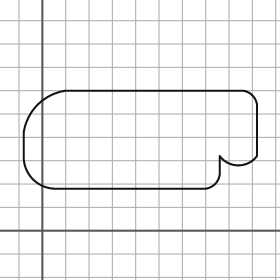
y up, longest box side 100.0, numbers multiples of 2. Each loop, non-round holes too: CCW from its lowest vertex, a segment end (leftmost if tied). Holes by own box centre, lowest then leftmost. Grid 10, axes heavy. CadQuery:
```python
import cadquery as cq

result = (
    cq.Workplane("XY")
    .moveTo(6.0, 18.0)
    .lineTo(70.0, 18.0)
    .threePointArc((74.0, 20.0), (76.0, 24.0))
    .lineTo(76.0, 32.0)
    .threePointArc((84.0, 28.0), (92.0, 32.0))
    .lineTo(92.0, 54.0)
    .threePointArc((90.0, 58.0), (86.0, 60.0))
    .lineTo(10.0, 60.0)
    .threePointArc((-2.0, 54.0), (-8.0, 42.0))
    .lineTo(-8.0, 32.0)
    .threePointArc((-4.0, 22.0), (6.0, 18.0))
    .close()
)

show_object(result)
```